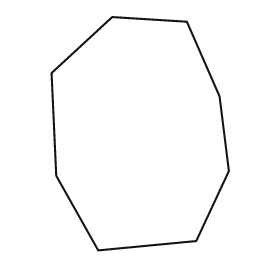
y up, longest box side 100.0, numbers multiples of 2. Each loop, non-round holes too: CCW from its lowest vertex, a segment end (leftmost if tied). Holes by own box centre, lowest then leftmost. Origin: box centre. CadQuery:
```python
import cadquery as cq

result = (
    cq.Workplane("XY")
    .moveTo(-18.0, -50.0)
    .lineTo(24.0, -46.0)
    .lineTo(38.0, -16.0)
    .lineTo(34.0, 16.0)
    .lineTo(20.0, 48.0)
    .lineTo(-12.0, 50.0)
    .lineTo(-38.0, 26.0)
    .lineTo(-36.0, -18.0)
    .close()
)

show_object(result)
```